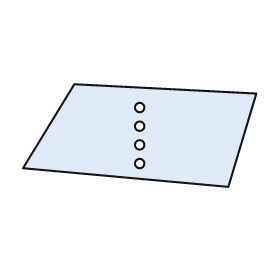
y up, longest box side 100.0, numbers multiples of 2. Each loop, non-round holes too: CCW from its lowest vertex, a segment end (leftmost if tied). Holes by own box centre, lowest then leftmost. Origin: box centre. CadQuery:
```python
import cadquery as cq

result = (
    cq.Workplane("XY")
    .moveTo(38.0, -22.0)
    .lineTo(50.0, 18.0)
    .lineTo(-28.0, 22.0)
    .lineTo(-50.0, -14.0)
    .close()
    .moveTo(0.0, -12.0)
    .circle(2.0)
    .moveTo(0.0, -4.0)
    .circle(2.0)
    .moveTo(0.0, 4.0)
    .circle(2.0)
    .moveTo(0.0, 12.0)
    .circle(2.0)
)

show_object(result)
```